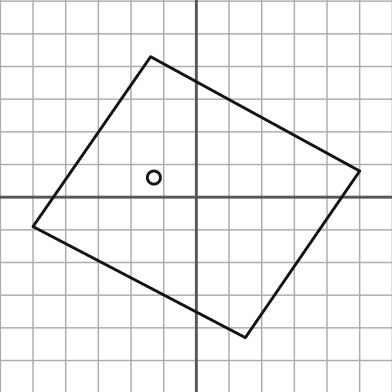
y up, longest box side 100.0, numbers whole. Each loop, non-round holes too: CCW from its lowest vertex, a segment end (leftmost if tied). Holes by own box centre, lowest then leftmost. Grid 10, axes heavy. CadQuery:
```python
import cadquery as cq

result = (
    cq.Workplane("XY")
    .moveTo(15.0, -43.0)
    .lineTo(50.0, 8.0)
    .lineTo(-14.0, 43.0)
    .lineTo(-50.0, -9.0)
    .close()
    .moveTo(-13.0, 6.0)
    .circle(2.0)
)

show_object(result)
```